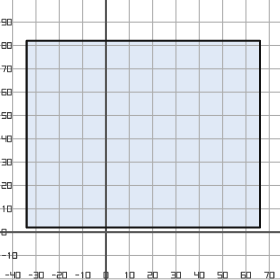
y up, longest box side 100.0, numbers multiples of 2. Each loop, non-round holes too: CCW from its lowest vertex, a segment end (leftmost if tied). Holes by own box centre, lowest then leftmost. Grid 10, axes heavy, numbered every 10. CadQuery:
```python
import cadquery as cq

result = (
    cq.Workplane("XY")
    .moveTo(-34.0, 2.0)
    .lineTo(66.0, 2.0)
    .lineTo(66.0, 82.0)
    .lineTo(-34.0, 82.0)
    .close()
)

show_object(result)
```